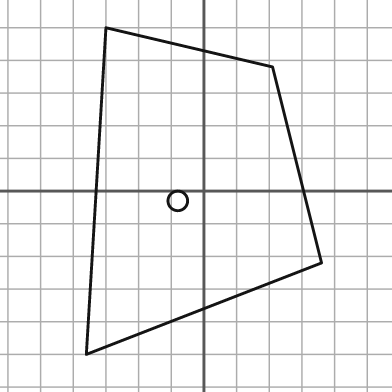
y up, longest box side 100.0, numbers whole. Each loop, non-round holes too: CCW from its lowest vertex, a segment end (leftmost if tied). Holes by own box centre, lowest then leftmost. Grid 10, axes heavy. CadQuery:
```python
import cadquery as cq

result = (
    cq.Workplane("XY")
    .moveTo(-36.0, -50.0)
    .lineTo(36.0, -22.0)
    .lineTo(21.0, 38.0)
    .lineTo(-30.0, 50.0)
    .close()
    .moveTo(-8.0, -3.0)
    .circle(3.0)
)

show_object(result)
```